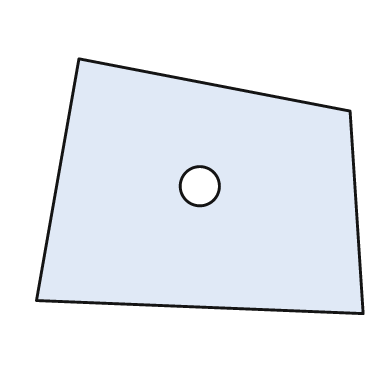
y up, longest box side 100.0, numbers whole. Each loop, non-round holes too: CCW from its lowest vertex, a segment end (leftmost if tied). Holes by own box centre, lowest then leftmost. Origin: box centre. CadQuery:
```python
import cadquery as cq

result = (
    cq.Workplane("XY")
    .moveTo(50.0, -39.0)
    .lineTo(46.0, 23.0)
    .lineTo(-37.0, 39.0)
    .lineTo(-50.0, -35.0)
    .close()
    .moveTo(0.0, 0.0)
    .circle(6.0)
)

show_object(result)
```